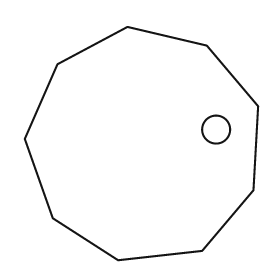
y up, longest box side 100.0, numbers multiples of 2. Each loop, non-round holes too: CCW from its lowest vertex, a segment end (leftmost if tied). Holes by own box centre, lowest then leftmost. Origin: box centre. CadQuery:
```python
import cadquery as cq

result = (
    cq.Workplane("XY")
    .moveTo(-10.0, -50.0)
    .lineTo(26.0, -46.0)
    .lineTo(48.0, -20.0)
    .lineTo(50.0, 16.0)
    .lineTo(28.0, 42.0)
    .lineTo(-6.0, 50.0)
    .lineTo(-36.0, 34.0)
    .lineTo(-50.0, 2.0)
    .lineTo(-38.0, -32.0)
    .close()
    .moveTo(32.0, 6.0)
    .circle(6.0)
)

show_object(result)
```